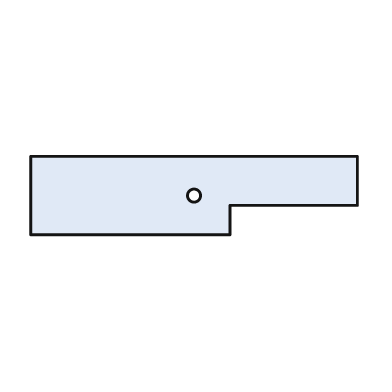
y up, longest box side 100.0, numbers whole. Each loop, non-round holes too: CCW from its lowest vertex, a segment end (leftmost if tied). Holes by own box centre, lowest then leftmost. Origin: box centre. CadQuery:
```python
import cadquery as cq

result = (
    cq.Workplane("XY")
    .moveTo(-50.0, -12.0)
    .lineTo(11.0, -12.0)
    .lineTo(11.0, -3.0)
    .lineTo(50.0, -3.0)
    .lineTo(50.0, 12.0)
    .lineTo(-50.0, 12.0)
    .close()
    .moveTo(0.0, 0.0)
    .circle(2.0)
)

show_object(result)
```